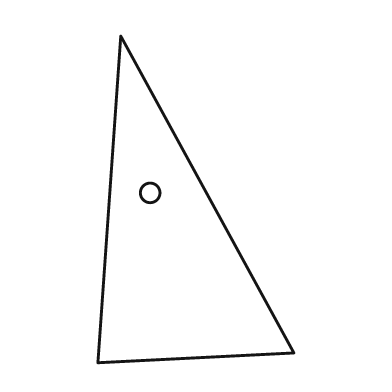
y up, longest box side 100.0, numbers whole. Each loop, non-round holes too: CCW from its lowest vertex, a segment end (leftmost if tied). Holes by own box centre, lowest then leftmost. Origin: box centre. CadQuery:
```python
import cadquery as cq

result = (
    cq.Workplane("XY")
    .moveTo(-30.0, -50.0)
    .lineTo(30.0, -47.0)
    .lineTo(-23.0, 50.0)
    .close()
    .moveTo(-14.0, 2.0)
    .circle(3.0)
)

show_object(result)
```